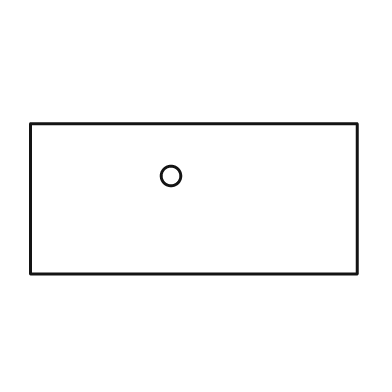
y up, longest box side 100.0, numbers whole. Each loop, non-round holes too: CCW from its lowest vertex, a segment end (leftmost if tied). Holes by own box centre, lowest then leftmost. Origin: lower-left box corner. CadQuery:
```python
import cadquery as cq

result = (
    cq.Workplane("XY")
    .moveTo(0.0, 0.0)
    .lineTo(100.0, 0.0)
    .lineTo(100.0, 46.0)
    .lineTo(0.0, 46.0)
    .close()
    .moveTo(43.0, 30.0)
    .circle(3.0)
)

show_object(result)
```